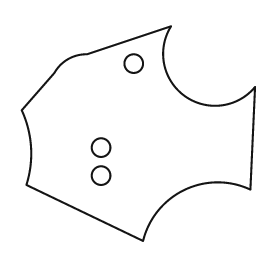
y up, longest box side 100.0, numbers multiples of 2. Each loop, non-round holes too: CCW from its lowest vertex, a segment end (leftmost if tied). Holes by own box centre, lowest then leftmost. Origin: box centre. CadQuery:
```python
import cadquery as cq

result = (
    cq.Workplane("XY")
    .moveTo(2.0, -46.0)
    .threePointArc((20.0, -24.0), (48.0, -24.0))
    .lineTo(50.0, 20.0)
    .threePointArc((20.0, 16.0), (14.0, 46.0))
    .lineTo(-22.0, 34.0)
    .threePointArc((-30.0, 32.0), (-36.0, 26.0))
    .lineTo(-50.0, 10.0)
    .threePointArc((-46.0, -6.0), (-48.0, -22.0))
    .close()
    .moveTo(-16.0, -18.0)
    .circle(4.0)
    .moveTo(-16.0, -6.0)
    .circle(4.0)
    .moveTo(-2.0, 30.0)
    .circle(4.0)
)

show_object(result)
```